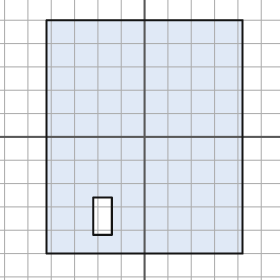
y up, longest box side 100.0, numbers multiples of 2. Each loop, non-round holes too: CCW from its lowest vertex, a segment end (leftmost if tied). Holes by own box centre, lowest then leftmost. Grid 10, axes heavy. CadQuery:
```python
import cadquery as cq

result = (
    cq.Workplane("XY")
    .moveTo(-42.0, -50.0)
    .lineTo(42.0, -50.0)
    .lineTo(42.0, 50.0)
    .lineTo(-42.0, 50.0)
    .close()
    .moveTo(-22.0, -42.0)
    .lineTo(-14.0, -42.0)
    .lineTo(-14.0, -26.0)
    .lineTo(-22.0, -26.0)
    .close()
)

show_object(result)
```